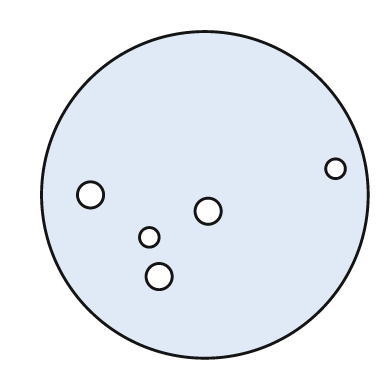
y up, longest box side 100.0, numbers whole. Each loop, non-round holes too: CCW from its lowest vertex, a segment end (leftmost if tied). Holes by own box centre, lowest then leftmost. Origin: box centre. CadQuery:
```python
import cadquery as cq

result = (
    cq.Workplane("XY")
    .moveTo(0.0, 0.0)
    .circle(50.0)
    .moveTo(-14.0, -25.0)
    .circle(4.0)
    .moveTo(-17.0, -13.0)
    .circle(3.0)
    .moveTo(1.0, -5.0)
    .circle(4.0)
    .moveTo(-35.0, 0.0)
    .circle(4.0)
    .moveTo(40.0, 8.0)
    .circle(3.0)
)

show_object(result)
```